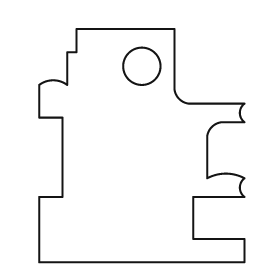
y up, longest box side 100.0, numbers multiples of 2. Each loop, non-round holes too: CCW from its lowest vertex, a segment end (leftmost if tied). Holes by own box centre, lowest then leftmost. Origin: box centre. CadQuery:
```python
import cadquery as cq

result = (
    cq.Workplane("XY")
    .moveTo(-44.0, -50.0)
    .lineTo(44.0, -50.0)
    .lineTo(44.0, -40.0)
    .lineTo(22.0, -40.0)
    .lineTo(22.0, -22.0)
    .lineTo(44.0, -22.0)
    .threePointArc((42.0, -18.0), (44.0, -14.0))
    .threePointArc((36.0, -12.0), (28.0, -14.0))
    .lineTo(28.0, 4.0)
    .threePointArc((30.0, 8.0), (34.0, 10.0))
    .lineTo(44.0, 10.0)
    .threePointArc((42.0, 14.0), (44.0, 18.0))
    .lineTo(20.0, 18.0)
    .threePointArc((16.0, 20.0), (14.0, 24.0))
    .lineTo(14.0, 50.0)
    .lineTo(-28.0, 50.0)
    .lineTo(-28.0, 40.0)
    .lineTo(-32.0, 40.0)
    .lineTo(-32.0, 26.0)
    .threePointArc((-38.0, 28.0), (-44.0, 26.0))
    .lineTo(-44.0, 12.0)
    .lineTo(-34.0, 12.0)
    .lineTo(-34.0, -22.0)
    .lineTo(-44.0, -22.0)
    .close()
    .moveTo(0.0, 34.0)
    .circle(8.0)
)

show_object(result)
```